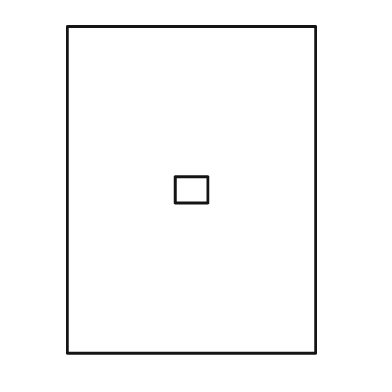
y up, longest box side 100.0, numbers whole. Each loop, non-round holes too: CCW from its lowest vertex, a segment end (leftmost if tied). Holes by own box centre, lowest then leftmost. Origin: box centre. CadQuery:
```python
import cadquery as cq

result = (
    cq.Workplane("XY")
    .moveTo(-38.0, -50.0)
    .lineTo(38.0, -50.0)
    .lineTo(38.0, 50.0)
    .lineTo(-38.0, 50.0)
    .close()
    .moveTo(-5.0, -4.0)
    .lineTo(5.0, -4.0)
    .lineTo(5.0, 4.0)
    .lineTo(-5.0, 4.0)
    .close()
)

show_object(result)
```